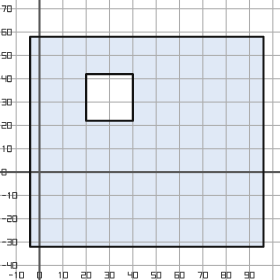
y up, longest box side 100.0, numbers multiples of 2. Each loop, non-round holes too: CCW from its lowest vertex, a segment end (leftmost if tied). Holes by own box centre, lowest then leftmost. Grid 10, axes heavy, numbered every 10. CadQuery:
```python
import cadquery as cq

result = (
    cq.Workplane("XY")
    .moveTo(-4.0, -32.0)
    .lineTo(96.0, -32.0)
    .lineTo(96.0, 58.0)
    .lineTo(-4.0, 58.0)
    .close()
    .moveTo(20.0, 22.0)
    .lineTo(40.0, 22.0)
    .lineTo(40.0, 42.0)
    .lineTo(20.0, 42.0)
    .close()
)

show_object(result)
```